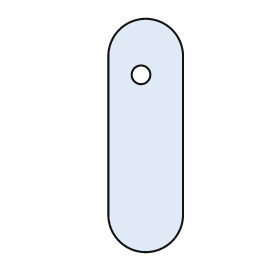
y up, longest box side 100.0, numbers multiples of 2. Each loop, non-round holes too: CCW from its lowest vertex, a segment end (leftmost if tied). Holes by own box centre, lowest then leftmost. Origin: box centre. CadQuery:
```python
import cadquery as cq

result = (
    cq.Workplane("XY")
    .moveTo(-16.0, -34.0)
    .threePointArc((0.0, -50.0), (16.0, -34.0))
    .lineTo(16.0, 34.0)
    .threePointArc((0.0, 50.0), (-16.0, 34.0))
    .close()
    .moveTo(-2.0, 26.0)
    .circle(4.0)
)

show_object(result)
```